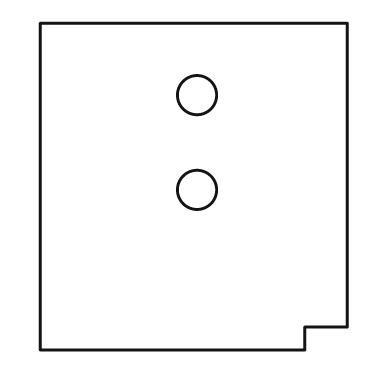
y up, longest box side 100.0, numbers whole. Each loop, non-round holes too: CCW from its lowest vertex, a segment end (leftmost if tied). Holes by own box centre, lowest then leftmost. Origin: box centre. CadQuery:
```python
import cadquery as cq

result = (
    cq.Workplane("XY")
    .moveTo(-47.0, -50.0)
    .lineTo(34.0, -50.0)
    .lineTo(34.0, -43.0)
    .lineTo(47.0, -43.0)
    .lineTo(47.0, 50.0)
    .lineTo(-47.0, 50.0)
    .close()
    .moveTo(1.0, -1.0)
    .circle(6.0)
    .moveTo(1.0, 28.0)
    .circle(6.0)
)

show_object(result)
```